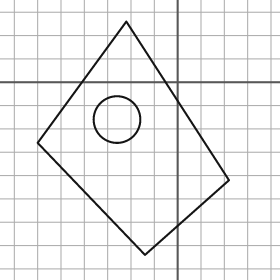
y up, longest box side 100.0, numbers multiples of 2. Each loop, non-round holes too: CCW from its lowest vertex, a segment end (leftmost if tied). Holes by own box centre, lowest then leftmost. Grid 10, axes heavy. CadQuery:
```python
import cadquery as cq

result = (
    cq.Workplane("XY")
    .moveTo(-14.0, -74.0)
    .lineTo(22.0, -42.0)
    .lineTo(-22.0, 26.0)
    .lineTo(-60.0, -26.0)
    .close()
    .moveTo(-26.0, -16.0)
    .circle(10.0)
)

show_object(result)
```